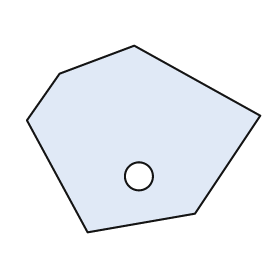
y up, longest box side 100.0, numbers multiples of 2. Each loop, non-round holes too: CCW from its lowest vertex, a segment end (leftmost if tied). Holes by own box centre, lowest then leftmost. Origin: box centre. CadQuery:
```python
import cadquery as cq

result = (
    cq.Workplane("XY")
    .moveTo(-24.0, -40.0)
    .lineTo(22.0, -32.0)
    .lineTo(50.0, 10.0)
    .lineTo(-4.0, 40.0)
    .lineTo(-36.0, 28.0)
    .lineTo(-50.0, 8.0)
    .close()
    .moveTo(-2.0, -16.0)
    .circle(6.0)
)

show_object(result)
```